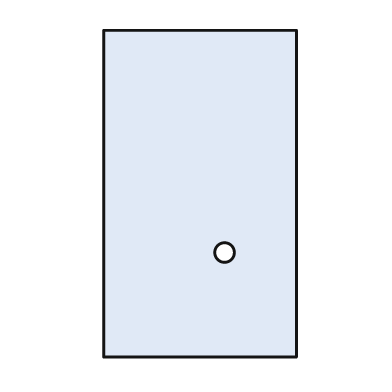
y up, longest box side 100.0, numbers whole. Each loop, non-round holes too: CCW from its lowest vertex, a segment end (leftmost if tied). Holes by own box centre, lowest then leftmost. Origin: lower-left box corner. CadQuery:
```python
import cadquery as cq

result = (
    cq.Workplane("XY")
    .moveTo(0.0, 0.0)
    .lineTo(59.0, 0.0)
    .lineTo(59.0, 100.0)
    .lineTo(0.0, 100.0)
    .close()
    .moveTo(37.0, 32.0)
    .circle(3.0)
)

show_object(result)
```